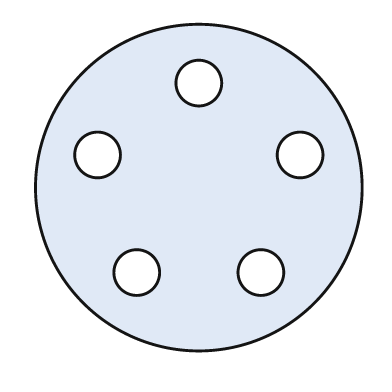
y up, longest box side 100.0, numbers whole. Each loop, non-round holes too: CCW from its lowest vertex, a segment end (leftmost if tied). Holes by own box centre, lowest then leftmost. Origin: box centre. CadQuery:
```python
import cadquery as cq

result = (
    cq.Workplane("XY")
    .moveTo(0.0, 0.0)
    .circle(50.0)
    .moveTo(-19.0, -26.0)
    .circle(7.0)
    .moveTo(19.0, -26.0)
    .circle(7.0)
    .moveTo(-31.0, 10.0)
    .circle(7.0)
    .moveTo(31.0, 10.0)
    .circle(7.0)
    .moveTo(0.0, 32.0)
    .circle(7.0)
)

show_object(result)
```